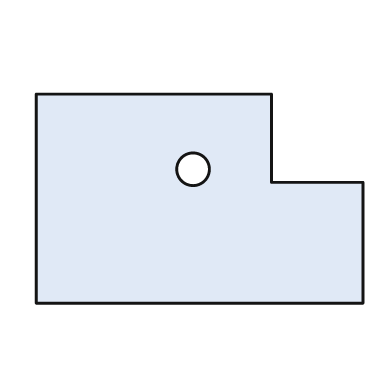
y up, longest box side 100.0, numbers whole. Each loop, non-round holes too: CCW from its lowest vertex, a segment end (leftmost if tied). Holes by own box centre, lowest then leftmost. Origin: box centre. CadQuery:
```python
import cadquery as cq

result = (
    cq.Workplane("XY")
    .moveTo(-50.0, -32.0)
    .lineTo(50.0, -32.0)
    .lineTo(50.0, 5.0)
    .lineTo(22.0, 5.0)
    .lineTo(22.0, 32.0)
    .lineTo(-50.0, 32.0)
    .close()
    .moveTo(-2.0, 9.0)
    .circle(5.0)
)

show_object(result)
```